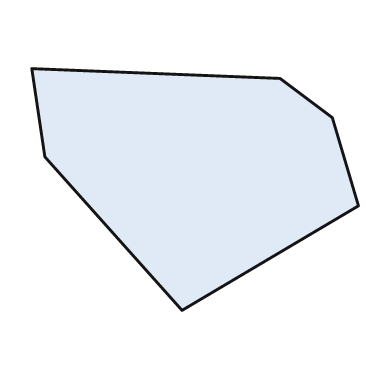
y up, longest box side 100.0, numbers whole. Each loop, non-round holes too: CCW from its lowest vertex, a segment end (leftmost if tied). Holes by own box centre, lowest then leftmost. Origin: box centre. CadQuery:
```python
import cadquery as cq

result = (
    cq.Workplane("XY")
    .moveTo(-4.0, -37.0)
    .lineTo(50.0, -5.0)
    .lineTo(42.0, 22.0)
    .lineTo(26.0, 34.0)
    .lineTo(-50.0, 37.0)
    .lineTo(-46.0, 10.0)
    .close()
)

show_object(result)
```